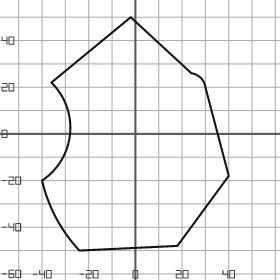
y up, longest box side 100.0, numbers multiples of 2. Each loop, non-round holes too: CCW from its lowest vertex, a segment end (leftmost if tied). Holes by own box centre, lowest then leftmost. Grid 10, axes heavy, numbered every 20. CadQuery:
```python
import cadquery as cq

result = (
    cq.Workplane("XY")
    .moveTo(-24.0, -50.0)
    .lineTo(18.0, -48.0)
    .lineTo(40.0, -18.0)
    .lineTo(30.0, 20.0)
    .threePointArc((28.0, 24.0), (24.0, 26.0))
    .lineTo(-2.0, 50.0)
    .lineTo(-36.0, 22.0)
    .threePointArc((-28.0, 0.0), (-40.0, -20.0))
    .threePointArc((-34.0, -36.0), (-24.0, -50.0))
    .close()
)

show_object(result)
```